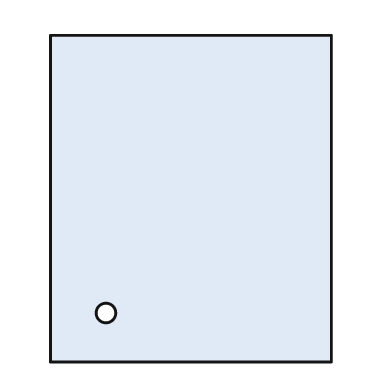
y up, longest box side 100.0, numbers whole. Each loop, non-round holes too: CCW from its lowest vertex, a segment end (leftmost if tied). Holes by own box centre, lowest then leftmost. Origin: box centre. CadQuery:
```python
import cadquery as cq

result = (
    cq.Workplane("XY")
    .moveTo(-43.0, -50.0)
    .lineTo(43.0, -50.0)
    .lineTo(43.0, 50.0)
    .lineTo(-43.0, 50.0)
    .close()
    .moveTo(-26.0, -35.0)
    .circle(3.0)
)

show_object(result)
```